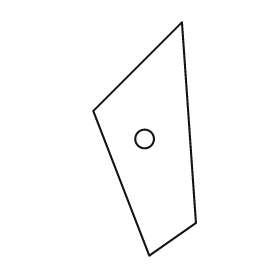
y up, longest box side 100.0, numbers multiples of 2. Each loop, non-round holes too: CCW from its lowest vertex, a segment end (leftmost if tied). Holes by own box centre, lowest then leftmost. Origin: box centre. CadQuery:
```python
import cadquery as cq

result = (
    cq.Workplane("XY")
    .moveTo(2.0, -50.0)
    .lineTo(22.0, -36.0)
    .lineTo(16.0, 50.0)
    .lineTo(-22.0, 12.0)
    .close()
    .moveTo(0.0, 0.0)
    .circle(4.0)
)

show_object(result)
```